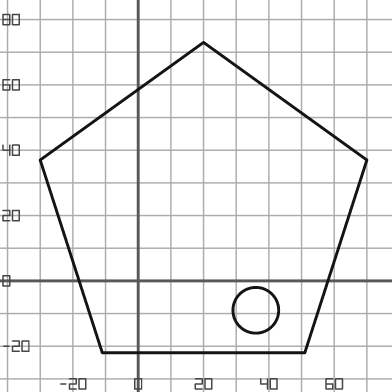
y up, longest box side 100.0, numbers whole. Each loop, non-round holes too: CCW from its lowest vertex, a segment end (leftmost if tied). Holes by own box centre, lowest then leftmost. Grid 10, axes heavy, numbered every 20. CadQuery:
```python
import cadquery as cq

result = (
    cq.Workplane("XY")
    .moveTo(-11.0, -22.0)
    .lineTo(51.0, -22.0)
    .lineTo(70.0, 37.0)
    .lineTo(20.0, 73.0)
    .lineTo(-30.0, 37.0)
    .close()
    .moveTo(36.0, -9.0)
    .circle(7.0)
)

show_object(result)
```